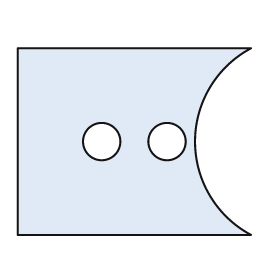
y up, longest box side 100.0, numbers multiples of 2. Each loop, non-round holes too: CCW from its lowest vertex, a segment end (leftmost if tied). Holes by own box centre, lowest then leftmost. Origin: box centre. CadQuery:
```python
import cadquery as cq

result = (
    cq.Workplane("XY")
    .moveTo(-50.0, -40.0)
    .lineTo(50.0, -40.0)
    .threePointArc((26.0, 0.0), (50.0, 40.0))
    .lineTo(-50.0, 40.0)
    .close()
    .moveTo(-14.0, 0.0)
    .circle(8.0)
    .moveTo(14.0, 0.0)
    .circle(8.0)
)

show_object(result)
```